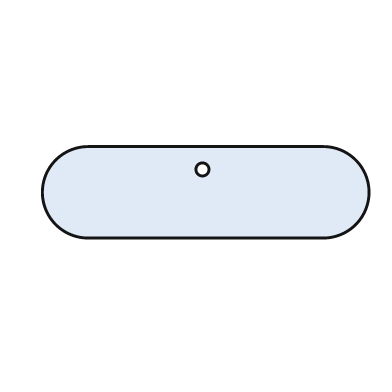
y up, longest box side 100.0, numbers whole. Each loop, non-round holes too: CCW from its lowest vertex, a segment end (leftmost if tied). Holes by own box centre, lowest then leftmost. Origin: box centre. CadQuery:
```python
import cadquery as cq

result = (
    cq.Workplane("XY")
    .moveTo(-36.0, -14.0)
    .lineTo(36.0, -14.0)
    .threePointArc((50.0, 0.0), (36.0, 14.0))
    .lineTo(-36.0, 14.0)
    .threePointArc((-50.0, 0.0), (-36.0, -14.0))
    .close()
    .moveTo(-1.0, 7.0)
    .circle(2.0)
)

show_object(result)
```